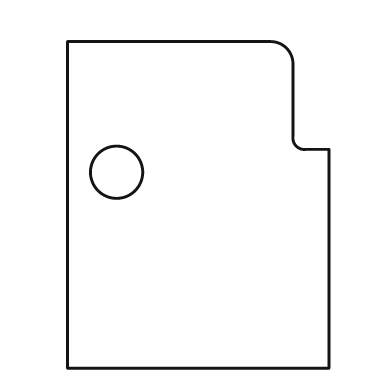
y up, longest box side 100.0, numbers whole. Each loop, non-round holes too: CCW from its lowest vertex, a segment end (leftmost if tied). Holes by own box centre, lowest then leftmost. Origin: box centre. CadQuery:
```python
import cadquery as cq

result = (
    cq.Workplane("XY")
    .moveTo(-40.0, -50.0)
    .lineTo(40.0, -50.0)
    .lineTo(40.0, 17.0)
    .lineTo(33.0, 17.0)
    .threePointArc((30.0, 18.0), (29.0, 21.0))
    .lineTo(29.0, 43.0)
    .threePointArc((27.0, 48.0), (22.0, 50.0))
    .lineTo(-40.0, 50.0)
    .close()
    .moveTo(-25.0, 10.0)
    .circle(8.0)
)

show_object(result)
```